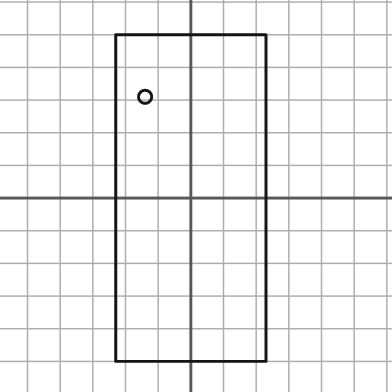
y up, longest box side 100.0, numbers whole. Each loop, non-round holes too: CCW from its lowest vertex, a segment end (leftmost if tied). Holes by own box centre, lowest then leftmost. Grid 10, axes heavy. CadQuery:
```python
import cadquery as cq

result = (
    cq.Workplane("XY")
    .moveTo(-23.0, -50.0)
    .lineTo(23.0, -50.0)
    .lineTo(23.0, 50.0)
    .lineTo(-23.0, 50.0)
    .close()
    .moveTo(-14.0, 31.0)
    .circle(2.0)
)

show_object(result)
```